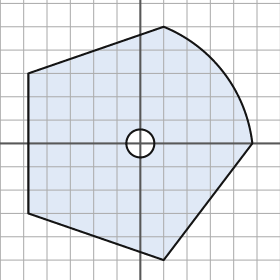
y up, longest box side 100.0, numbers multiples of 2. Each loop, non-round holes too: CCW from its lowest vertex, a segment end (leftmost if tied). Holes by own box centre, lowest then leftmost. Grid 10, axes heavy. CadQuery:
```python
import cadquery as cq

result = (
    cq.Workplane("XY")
    .moveTo(10.0, -50.0)
    .lineTo(48.0, 0.0)
    .threePointArc((36.0, 30.0), (10.0, 50.0))
    .lineTo(-48.0, 30.0)
    .lineTo(-48.0, -30.0)
    .close()
    .moveTo(0.0, 0.0)
    .circle(6.0)
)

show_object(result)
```